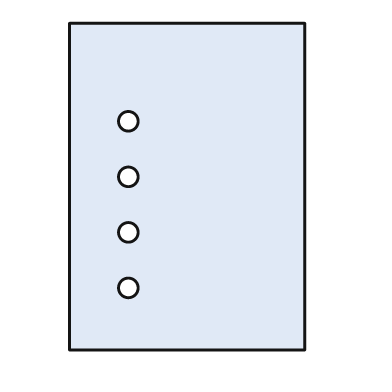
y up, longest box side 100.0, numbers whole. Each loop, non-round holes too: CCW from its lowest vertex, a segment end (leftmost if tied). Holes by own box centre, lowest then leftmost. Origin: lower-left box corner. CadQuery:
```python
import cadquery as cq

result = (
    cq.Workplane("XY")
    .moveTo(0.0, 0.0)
    .lineTo(72.0, 0.0)
    .lineTo(72.0, 100.0)
    .lineTo(0.0, 100.0)
    .close()
    .moveTo(18.0, 19.0)
    .circle(3.0)
    .moveTo(18.0, 36.0)
    .circle(3.0)
    .moveTo(18.0, 53.0)
    .circle(3.0)
    .moveTo(18.0, 70.0)
    .circle(3.0)
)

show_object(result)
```